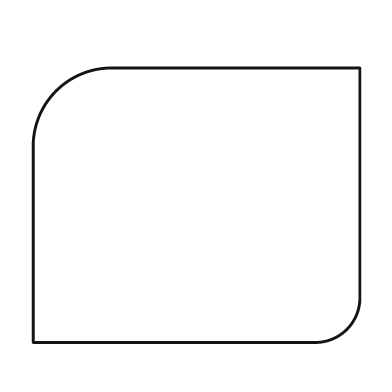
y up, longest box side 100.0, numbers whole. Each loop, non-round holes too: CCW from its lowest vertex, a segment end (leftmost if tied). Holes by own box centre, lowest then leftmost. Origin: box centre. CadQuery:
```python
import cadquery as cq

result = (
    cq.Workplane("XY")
    .moveTo(-50.0, -42.0)
    .lineTo(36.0, -42.0)
    .threePointArc((46.0, -38.0), (50.0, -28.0))
    .lineTo(50.0, 42.0)
    .lineTo(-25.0, 42.0)
    .threePointArc((-43.0, 35.0), (-50.0, 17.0))
    .close()
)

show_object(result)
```